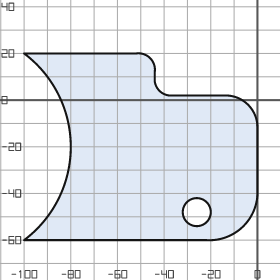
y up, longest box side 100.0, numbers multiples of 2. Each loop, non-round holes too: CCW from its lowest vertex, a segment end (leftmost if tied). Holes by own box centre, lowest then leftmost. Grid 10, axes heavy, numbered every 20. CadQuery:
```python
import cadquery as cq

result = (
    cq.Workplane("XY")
    .moveTo(-100.0, -60.0)
    .lineTo(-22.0, -60.0)
    .threePointArc((-6.0, -54.0), (0.0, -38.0))
    .lineTo(0.0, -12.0)
    .threePointArc((-4.0, -2.0), (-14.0, 2.0))
    .lineTo(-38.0, 2.0)
    .threePointArc((-42.0, 4.0), (-44.0, 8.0))
    .lineTo(-44.0, 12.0)
    .threePointArc((-46.0, 18.0), (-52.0, 20.0))
    .lineTo(-100.0, 20.0)
    .threePointArc((-80.0, -20.0), (-100.0, -60.0))
    .close()
    .moveTo(-26.0, -48.0)
    .circle(6.0)
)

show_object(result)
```